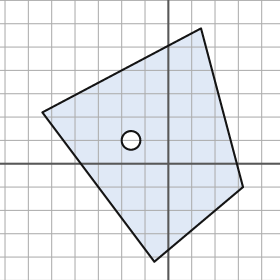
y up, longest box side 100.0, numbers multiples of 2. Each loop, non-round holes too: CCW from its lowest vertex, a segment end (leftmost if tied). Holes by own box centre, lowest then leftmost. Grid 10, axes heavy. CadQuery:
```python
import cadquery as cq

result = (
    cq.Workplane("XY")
    .moveTo(-6.0, -42.0)
    .lineTo(32.0, -10.0)
    .lineTo(14.0, 58.0)
    .lineTo(-54.0, 22.0)
    .close()
    .moveTo(-16.0, 10.0)
    .circle(4.0)
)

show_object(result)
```